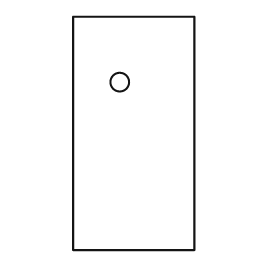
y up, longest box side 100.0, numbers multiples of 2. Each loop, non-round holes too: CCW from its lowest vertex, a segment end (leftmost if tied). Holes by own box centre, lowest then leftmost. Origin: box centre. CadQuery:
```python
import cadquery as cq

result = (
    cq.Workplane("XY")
    .moveTo(-26.0, -50.0)
    .lineTo(26.0, -50.0)
    .lineTo(26.0, 50.0)
    .lineTo(-26.0, 50.0)
    .close()
    .moveTo(-6.0, 22.0)
    .circle(4.0)
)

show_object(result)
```